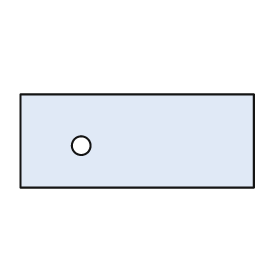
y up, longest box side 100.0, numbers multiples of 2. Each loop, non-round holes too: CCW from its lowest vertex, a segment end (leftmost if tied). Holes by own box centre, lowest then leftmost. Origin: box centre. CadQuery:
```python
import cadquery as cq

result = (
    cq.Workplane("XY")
    .moveTo(-50.0, -20.0)
    .lineTo(50.0, -20.0)
    .lineTo(50.0, 20.0)
    .lineTo(-50.0, 20.0)
    .close()
    .moveTo(-24.0, -2.0)
    .circle(4.0)
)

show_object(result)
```